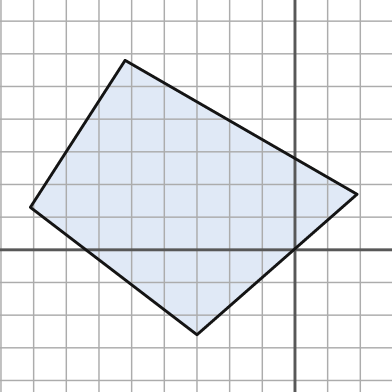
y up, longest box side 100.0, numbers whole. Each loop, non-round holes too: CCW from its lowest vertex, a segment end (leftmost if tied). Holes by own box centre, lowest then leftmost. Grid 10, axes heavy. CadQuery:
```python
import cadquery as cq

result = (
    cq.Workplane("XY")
    .moveTo(-30.0, -26.0)
    .lineTo(19.0, 17.0)
    .lineTo(-52.0, 58.0)
    .lineTo(-81.0, 13.0)
    .close()
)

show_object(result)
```